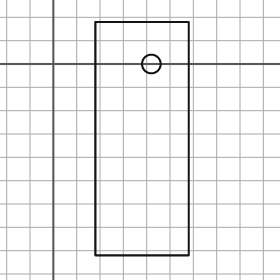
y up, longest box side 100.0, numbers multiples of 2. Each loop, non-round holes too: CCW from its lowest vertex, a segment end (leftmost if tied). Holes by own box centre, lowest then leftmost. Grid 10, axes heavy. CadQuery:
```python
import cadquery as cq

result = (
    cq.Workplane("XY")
    .moveTo(18.0, -82.0)
    .lineTo(58.0, -82.0)
    .lineTo(58.0, 18.0)
    .lineTo(18.0, 18.0)
    .close()
    .moveTo(42.0, 0.0)
    .circle(4.0)
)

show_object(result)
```